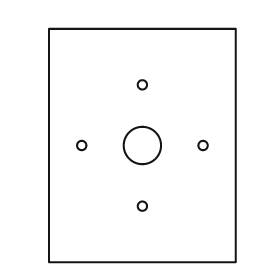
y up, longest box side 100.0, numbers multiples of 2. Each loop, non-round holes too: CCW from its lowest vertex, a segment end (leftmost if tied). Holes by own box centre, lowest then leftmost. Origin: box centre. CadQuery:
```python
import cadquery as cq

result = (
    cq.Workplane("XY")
    .moveTo(-40.0, -50.0)
    .lineTo(40.0, -50.0)
    .lineTo(40.0, 50.0)
    .lineTo(-40.0, 50.0)
    .close()
    .moveTo(0.0, -26.0)
    .circle(2.0)
    .moveTo(-26.0, 0.0)
    .circle(2.0)
    .moveTo(0.0, 0.0)
    .circle(8.0)
    .moveTo(26.0, 0.0)
    .circle(2.0)
    .moveTo(0.0, 26.0)
    .circle(2.0)
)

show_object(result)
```